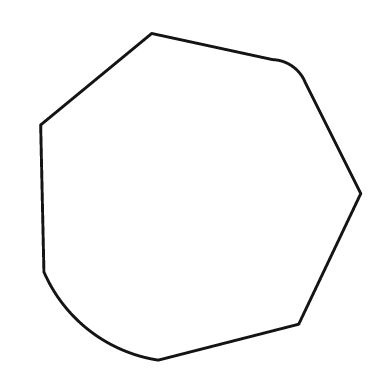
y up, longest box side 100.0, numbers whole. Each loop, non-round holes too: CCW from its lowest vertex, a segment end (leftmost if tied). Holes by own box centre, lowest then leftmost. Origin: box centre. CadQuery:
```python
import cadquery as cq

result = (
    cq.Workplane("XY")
    .moveTo(-13.0, -50.0)
    .lineTo(30.0, -39.0)
    .lineTo(49.0, 1.0)
    .lineTo(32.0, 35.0)
    .threePointArc((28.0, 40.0), (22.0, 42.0))
    .lineTo(-15.0, 50.0)
    .lineTo(-49.0, 22.0)
    .lineTo(-48.0, -23.0)
    .threePointArc((-34.0, -41.0), (-13.0, -50.0))
    .close()
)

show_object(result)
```